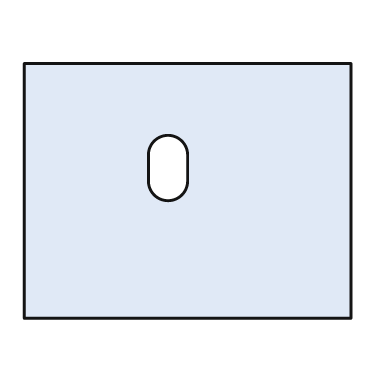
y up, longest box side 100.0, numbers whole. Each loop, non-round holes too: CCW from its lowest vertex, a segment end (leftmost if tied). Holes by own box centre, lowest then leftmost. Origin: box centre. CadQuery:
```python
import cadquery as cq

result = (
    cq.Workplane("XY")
    .moveTo(-50.0, -39.0)
    .lineTo(50.0, -39.0)
    .lineTo(50.0, 39.0)
    .lineTo(-50.0, 39.0)
    .close()
    .moveTo(-12.0, 3.0)
    .threePointArc((-6.0, -3.0), (0.0, 3.0))
    .lineTo(0.0, 11.0)
    .threePointArc((-6.0, 17.0), (-12.0, 11.0))
    .close()
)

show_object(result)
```